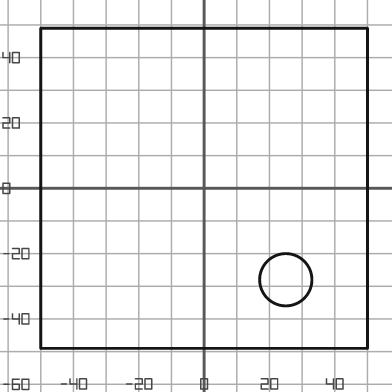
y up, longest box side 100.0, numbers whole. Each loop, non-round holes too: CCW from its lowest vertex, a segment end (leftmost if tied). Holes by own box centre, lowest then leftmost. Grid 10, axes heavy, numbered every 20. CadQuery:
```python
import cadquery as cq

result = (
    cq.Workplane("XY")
    .moveTo(-50.0, -49.0)
    .lineTo(50.0, -49.0)
    .lineTo(50.0, 49.0)
    .lineTo(-50.0, 49.0)
    .close()
    .moveTo(25.0, -28.0)
    .circle(8.0)
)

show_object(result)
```